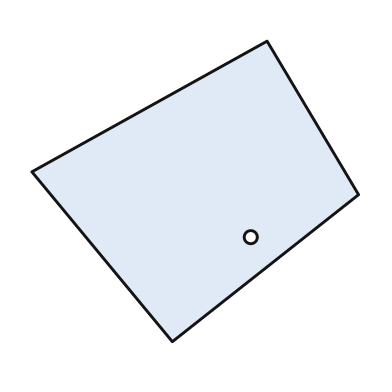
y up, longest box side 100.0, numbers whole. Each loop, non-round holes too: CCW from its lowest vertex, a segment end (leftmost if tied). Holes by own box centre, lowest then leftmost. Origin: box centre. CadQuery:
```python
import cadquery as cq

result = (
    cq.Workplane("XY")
    .moveTo(-7.0, -46.0)
    .lineTo(50.0, -1.0)
    .lineTo(22.0, 46.0)
    .lineTo(-50.0, 6.0)
    .close()
    .moveTo(17.0, -14.0)
    .circle(2.0)
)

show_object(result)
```